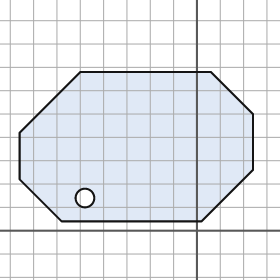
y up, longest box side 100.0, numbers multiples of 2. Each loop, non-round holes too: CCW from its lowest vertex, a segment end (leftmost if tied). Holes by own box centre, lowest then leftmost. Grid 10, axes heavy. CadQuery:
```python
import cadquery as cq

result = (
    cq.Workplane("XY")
    .moveTo(-58.0, 4.0)
    .lineTo(2.0, 4.0)
    .lineTo(24.0, 26.0)
    .lineTo(24.0, 50.0)
    .lineTo(6.0, 68.0)
    .lineTo(-50.0, 68.0)
    .lineTo(-76.0, 42.0)
    .lineTo(-76.0, 22.0)
    .close()
    .moveTo(-48.0, 14.0)
    .circle(4.0)
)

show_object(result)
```